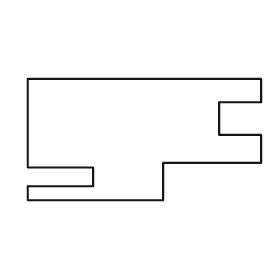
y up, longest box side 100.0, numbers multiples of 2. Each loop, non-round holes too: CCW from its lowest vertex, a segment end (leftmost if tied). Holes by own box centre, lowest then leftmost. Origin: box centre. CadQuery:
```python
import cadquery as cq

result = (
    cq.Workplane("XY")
    .moveTo(-50.0, -26.0)
    .lineTo(8.0, -26.0)
    .lineTo(8.0, -10.0)
    .lineTo(50.0, -10.0)
    .lineTo(50.0, 2.0)
    .lineTo(32.0, 2.0)
    .lineTo(32.0, 16.0)
    .lineTo(50.0, 16.0)
    .lineTo(50.0, 26.0)
    .lineTo(-50.0, 26.0)
    .lineTo(-50.0, -12.0)
    .lineTo(-22.0, -12.0)
    .lineTo(-22.0, -20.0)
    .lineTo(-50.0, -20.0)
    .close()
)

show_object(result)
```